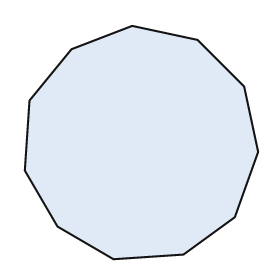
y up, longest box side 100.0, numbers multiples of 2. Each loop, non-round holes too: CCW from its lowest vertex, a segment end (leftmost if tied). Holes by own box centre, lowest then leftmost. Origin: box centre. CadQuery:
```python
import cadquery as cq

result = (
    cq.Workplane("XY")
    .moveTo(-12.0, -50.0)
    .lineTo(18.0, -48.0)
    .lineTo(40.0, -32.0)
    .lineTo(50.0, -4.0)
    .lineTo(44.0, 24.0)
    .lineTo(24.0, 44.0)
    .lineTo(-4.0, 50.0)
    .lineTo(-30.0, 40.0)
    .lineTo(-48.0, 18.0)
    .lineTo(-50.0, -12.0)
    .lineTo(-36.0, -36.0)
    .close()
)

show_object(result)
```